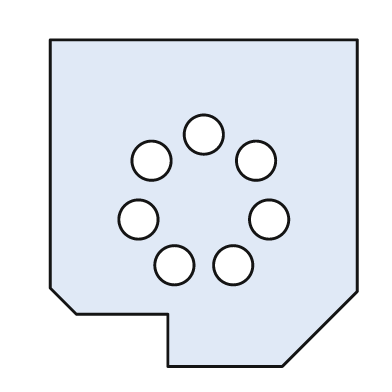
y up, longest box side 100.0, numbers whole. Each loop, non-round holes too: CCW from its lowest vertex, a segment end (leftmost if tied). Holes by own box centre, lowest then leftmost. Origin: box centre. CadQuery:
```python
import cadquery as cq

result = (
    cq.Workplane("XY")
    .moveTo(-11.0, -50.0)
    .lineTo(24.0, -50.0)
    .lineTo(47.0, -27.0)
    .lineTo(47.0, 50.0)
    .lineTo(-47.0, 50.0)
    .lineTo(-47.0, -26.0)
    .lineTo(-39.0, -34.0)
    .lineTo(-11.0, -34.0)
    .close()
    .moveTo(-9.0, -19.0)
    .circle(6.0)
    .moveTo(9.0, -19.0)
    .circle(6.0)
    .moveTo(-20.0, -5.0)
    .circle(6.0)
    .moveTo(20.0, -5.0)
    .circle(6.0)
    .moveTo(-16.0, 13.0)
    .circle(6.0)
    .moveTo(16.0, 13.0)
    .circle(6.0)
    .moveTo(0.0, 21.0)
    .circle(6.0)
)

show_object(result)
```